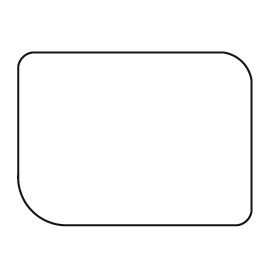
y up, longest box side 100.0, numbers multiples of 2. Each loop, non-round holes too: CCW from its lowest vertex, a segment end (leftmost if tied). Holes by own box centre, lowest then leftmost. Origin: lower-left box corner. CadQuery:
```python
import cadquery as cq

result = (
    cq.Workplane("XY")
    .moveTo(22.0, 0.0)
    .lineTo(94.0, 0.0)
    .threePointArc((98.0, 2.0), (100.0, 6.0))
    .lineTo(100.0, 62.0)
    .threePointArc((96.0, 70.0), (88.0, 74.0))
    .lineTo(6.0, 74.0)
    .threePointArc((2.0, 72.0), (0.0, 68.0))
    .lineTo(0.0, 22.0)
    .threePointArc((6.0, 6.0), (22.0, 0.0))
    .close()
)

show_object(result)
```